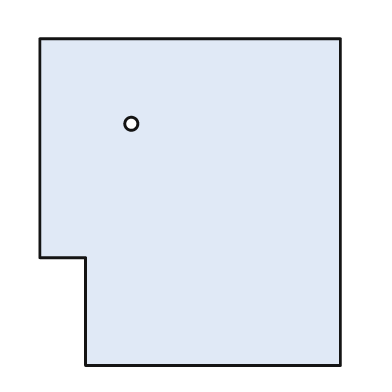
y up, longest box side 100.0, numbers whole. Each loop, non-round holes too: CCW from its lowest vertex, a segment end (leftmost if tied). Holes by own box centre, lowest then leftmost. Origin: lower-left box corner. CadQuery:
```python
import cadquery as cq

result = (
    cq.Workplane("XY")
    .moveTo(14.0, 0.0)
    .lineTo(92.0, 0.0)
    .lineTo(92.0, 100.0)
    .lineTo(0.0, 100.0)
    .lineTo(0.0, 33.0)
    .lineTo(14.0, 33.0)
    .close()
    .moveTo(28.0, 74.0)
    .circle(2.0)
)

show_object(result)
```